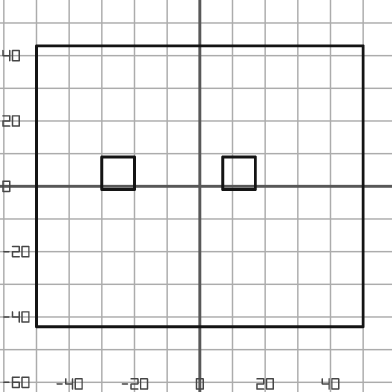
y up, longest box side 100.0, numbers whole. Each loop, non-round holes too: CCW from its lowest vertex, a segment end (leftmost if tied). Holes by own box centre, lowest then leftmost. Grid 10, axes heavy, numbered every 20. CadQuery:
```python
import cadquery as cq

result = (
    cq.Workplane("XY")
    .moveTo(-50.0, -43.0)
    .lineTo(50.0, -43.0)
    .lineTo(50.0, 43.0)
    .lineTo(-50.0, 43.0)
    .close()
    .moveTo(-30.0, -1.0)
    .lineTo(-20.0, -1.0)
    .lineTo(-20.0, 9.0)
    .lineTo(-30.0, 9.0)
    .close()
    .moveTo(7.0, -1.0)
    .lineTo(17.0, -1.0)
    .lineTo(17.0, 9.0)
    .lineTo(7.0, 9.0)
    .close()
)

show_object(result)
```